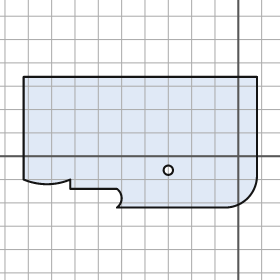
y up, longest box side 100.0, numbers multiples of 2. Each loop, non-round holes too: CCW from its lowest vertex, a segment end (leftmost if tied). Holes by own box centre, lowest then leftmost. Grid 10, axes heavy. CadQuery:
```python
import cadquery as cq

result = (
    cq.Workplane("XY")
    .moveTo(-52.0, -22.0)
    .lineTo(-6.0, -22.0)
    .threePointArc((4.0, -18.0), (8.0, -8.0))
    .lineTo(8.0, 34.0)
    .lineTo(-92.0, 34.0)
    .lineTo(-92.0, -10.0)
    .threePointArc((-82.0, -12.0), (-72.0, -10.0))
    .lineTo(-72.0, -14.0)
    .lineTo(-52.0, -14.0)
    .threePointArc((-50.0, -18.0), (-52.0, -22.0))
    .close()
    .moveTo(-30.0, -6.0)
    .circle(2.0)
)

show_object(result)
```